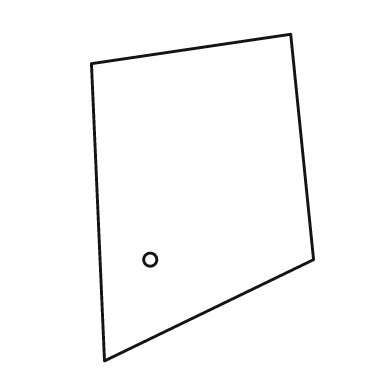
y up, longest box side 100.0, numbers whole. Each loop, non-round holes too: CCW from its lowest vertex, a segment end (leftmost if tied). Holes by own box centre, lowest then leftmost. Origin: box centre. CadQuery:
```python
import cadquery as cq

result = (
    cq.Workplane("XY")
    .moveTo(-30.0, -50.0)
    .lineTo(34.0, -19.0)
    .lineTo(27.0, 50.0)
    .lineTo(-34.0, 41.0)
    .close()
    .moveTo(-16.0, -19.0)
    .circle(2.0)
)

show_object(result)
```